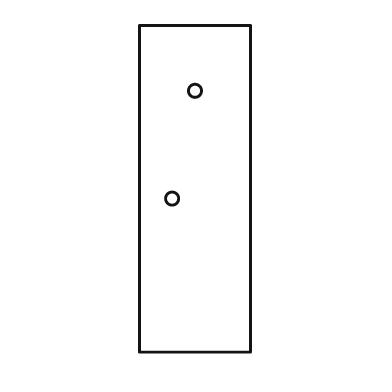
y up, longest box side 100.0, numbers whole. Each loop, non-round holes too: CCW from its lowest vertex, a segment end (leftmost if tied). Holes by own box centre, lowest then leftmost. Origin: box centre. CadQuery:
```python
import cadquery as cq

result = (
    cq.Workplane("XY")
    .moveTo(-17.0, -50.0)
    .lineTo(17.0, -50.0)
    .lineTo(17.0, 50.0)
    .lineTo(-17.0, 50.0)
    .close()
    .moveTo(-7.0, -3.0)
    .circle(2.0)
    .moveTo(0.0, 30.0)
    .circle(2.0)
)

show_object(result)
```